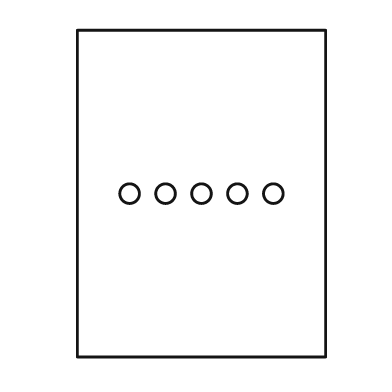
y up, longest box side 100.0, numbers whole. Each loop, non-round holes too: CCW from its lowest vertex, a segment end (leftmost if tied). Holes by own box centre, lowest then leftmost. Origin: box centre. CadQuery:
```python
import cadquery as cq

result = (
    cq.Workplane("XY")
    .moveTo(-38.0, -50.0)
    .lineTo(38.0, -50.0)
    .lineTo(38.0, 50.0)
    .lineTo(-38.0, 50.0)
    .close()
    .moveTo(-22.0, 0.0)
    .circle(3.0)
    .moveTo(-11.0, 0.0)
    .circle(3.0)
    .moveTo(0.0, 0.0)
    .circle(3.0)
    .moveTo(11.0, 0.0)
    .circle(3.0)
    .moveTo(22.0, 0.0)
    .circle(3.0)
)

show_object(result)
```